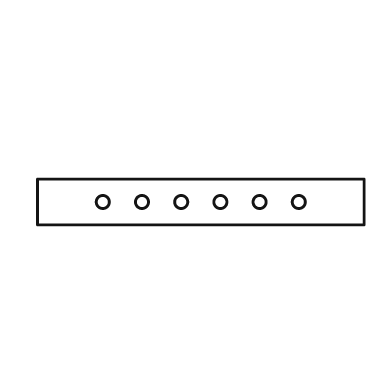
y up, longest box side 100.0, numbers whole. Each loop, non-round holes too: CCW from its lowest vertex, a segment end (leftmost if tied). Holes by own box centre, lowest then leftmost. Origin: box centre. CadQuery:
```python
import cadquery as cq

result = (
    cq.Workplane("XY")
    .moveTo(-50.0, -7.0)
    .lineTo(50.0, -7.0)
    .lineTo(50.0, 7.0)
    .lineTo(-50.0, 7.0)
    .close()
    .moveTo(-30.0, 0.0)
    .circle(2.0)
    .moveTo(-18.0, 0.0)
    .circle(2.0)
    .moveTo(-6.0, 0.0)
    .circle(2.0)
    .moveTo(6.0, 0.0)
    .circle(2.0)
    .moveTo(18.0, 0.0)
    .circle(2.0)
    .moveTo(30.0, 0.0)
    .circle(2.0)
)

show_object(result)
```